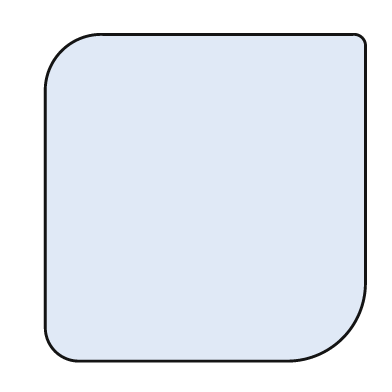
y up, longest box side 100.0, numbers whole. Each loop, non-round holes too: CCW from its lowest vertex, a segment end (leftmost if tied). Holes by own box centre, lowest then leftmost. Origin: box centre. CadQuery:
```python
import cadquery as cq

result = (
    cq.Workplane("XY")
    .moveTo(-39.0, -50.0)
    .lineTo(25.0, -50.0)
    .threePointArc((42.0, -43.0), (49.0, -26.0))
    .lineTo(49.0, 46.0)
    .threePointArc((48.0, 49.0), (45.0, 50.0))
    .lineTo(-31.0, 50.0)
    .threePointArc((-44.0, 45.0), (-49.0, 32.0))
    .lineTo(-49.0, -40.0)
    .threePointArc((-46.0, -47.0), (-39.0, -50.0))
    .close()
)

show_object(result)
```